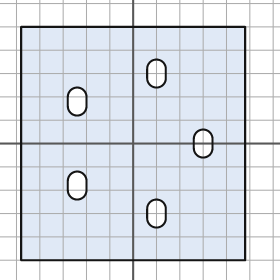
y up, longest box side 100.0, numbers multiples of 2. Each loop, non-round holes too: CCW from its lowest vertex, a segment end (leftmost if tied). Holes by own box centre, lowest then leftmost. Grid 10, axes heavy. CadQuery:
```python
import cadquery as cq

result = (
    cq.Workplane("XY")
    .moveTo(-48.0, -50.0)
    .lineTo(48.0, -50.0)
    .lineTo(48.0, 50.0)
    .lineTo(-48.0, 50.0)
    .close()
    .moveTo(6.0, -32.0)
    .threePointArc((10.0, -36.0), (14.0, -32.0))
    .lineTo(14.0, -28.0)
    .threePointArc((10.0, -24.0), (6.0, -28.0))
    .close()
    .moveTo(-28.0, -20.0)
    .threePointArc((-24.0, -24.0), (-20.0, -20.0))
    .lineTo(-20.0, -16.0)
    .threePointArc((-24.0, -12.0), (-28.0, -16.0))
    .close()
    .moveTo(26.0, -2.0)
    .threePointArc((30.0, -6.0), (34.0, -2.0))
    .lineTo(34.0, 2.0)
    .threePointArc((30.0, 6.0), (26.0, 2.0))
    .close()
    .moveTo(-28.0, 16.0)
    .threePointArc((-24.0, 12.0), (-20.0, 16.0))
    .lineTo(-20.0, 20.0)
    .threePointArc((-24.0, 24.0), (-28.0, 20.0))
    .close()
    .moveTo(6.0, 28.0)
    .threePointArc((10.0, 24.0), (14.0, 28.0))
    .lineTo(14.0, 32.0)
    .threePointArc((10.0, 36.0), (6.0, 32.0))
    .close()
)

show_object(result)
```